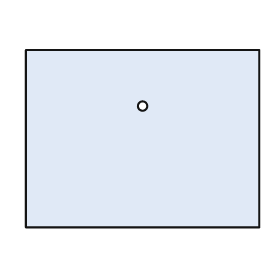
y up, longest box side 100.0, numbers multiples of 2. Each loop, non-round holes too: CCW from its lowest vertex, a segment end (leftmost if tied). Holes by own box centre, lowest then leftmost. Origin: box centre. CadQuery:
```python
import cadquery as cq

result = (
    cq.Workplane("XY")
    .moveTo(-50.0, -38.0)
    .lineTo(50.0, -38.0)
    .lineTo(50.0, 38.0)
    .lineTo(-50.0, 38.0)
    .close()
    .moveTo(0.0, 14.0)
    .circle(2.0)
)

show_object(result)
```